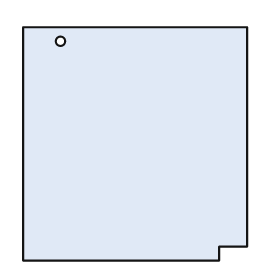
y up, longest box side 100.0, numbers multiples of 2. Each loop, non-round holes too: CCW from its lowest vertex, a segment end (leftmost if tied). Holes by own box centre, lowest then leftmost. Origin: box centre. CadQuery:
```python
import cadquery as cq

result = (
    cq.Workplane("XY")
    .moveTo(-48.0, -50.0)
    .lineTo(36.0, -50.0)
    .lineTo(36.0, -44.0)
    .lineTo(48.0, -44.0)
    .lineTo(48.0, 50.0)
    .lineTo(-48.0, 50.0)
    .close()
    .moveTo(-32.0, 44.0)
    .circle(2.0)
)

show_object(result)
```